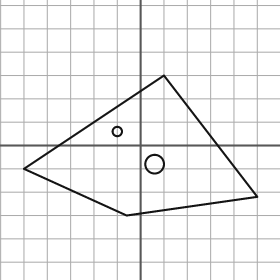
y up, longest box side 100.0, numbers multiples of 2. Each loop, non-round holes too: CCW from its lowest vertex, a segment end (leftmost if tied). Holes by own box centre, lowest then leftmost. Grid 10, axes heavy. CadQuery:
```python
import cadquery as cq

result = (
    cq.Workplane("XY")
    .moveTo(-6.0, -30.0)
    .lineTo(50.0, -22.0)
    .lineTo(10.0, 30.0)
    .lineTo(-50.0, -10.0)
    .close()
    .moveTo(6.0, -8.0)
    .circle(4.0)
    .moveTo(-10.0, 6.0)
    .circle(2.0)
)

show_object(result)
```